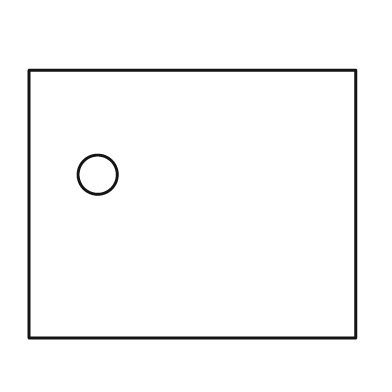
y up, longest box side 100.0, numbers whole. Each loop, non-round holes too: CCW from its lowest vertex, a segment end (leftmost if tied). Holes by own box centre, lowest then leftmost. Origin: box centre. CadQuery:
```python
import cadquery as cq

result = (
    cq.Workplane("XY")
    .moveTo(-50.0, -41.0)
    .lineTo(50.0, -41.0)
    .lineTo(50.0, 41.0)
    .lineTo(-50.0, 41.0)
    .close()
    .moveTo(-29.0, 9.0)
    .circle(6.0)
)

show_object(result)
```